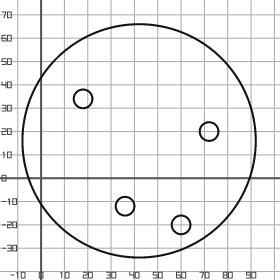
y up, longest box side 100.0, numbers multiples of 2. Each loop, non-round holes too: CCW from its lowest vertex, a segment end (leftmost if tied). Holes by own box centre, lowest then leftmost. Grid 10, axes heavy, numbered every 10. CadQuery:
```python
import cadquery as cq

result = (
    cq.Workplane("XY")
    .moveTo(42.0, 16.0)
    .circle(50.0)
    .moveTo(60.0, -20.0)
    .circle(4.0)
    .moveTo(36.0, -12.0)
    .circle(4.0)
    .moveTo(72.0, 20.0)
    .circle(4.0)
    .moveTo(18.0, 34.0)
    .circle(4.0)
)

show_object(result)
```